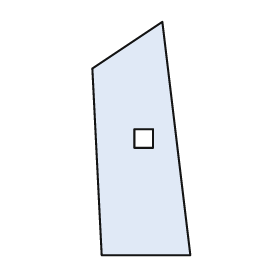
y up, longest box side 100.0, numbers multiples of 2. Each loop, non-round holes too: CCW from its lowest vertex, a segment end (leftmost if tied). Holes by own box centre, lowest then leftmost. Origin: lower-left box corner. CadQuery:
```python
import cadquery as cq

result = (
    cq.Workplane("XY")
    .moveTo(4.0, 0.0)
    .lineTo(42.0, 0.0)
    .lineTo(30.0, 100.0)
    .lineTo(0.0, 80.0)
    .close()
    .moveTo(18.0, 46.0)
    .lineTo(26.0, 46.0)
    .lineTo(26.0, 54.0)
    .lineTo(18.0, 54.0)
    .close()
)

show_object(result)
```